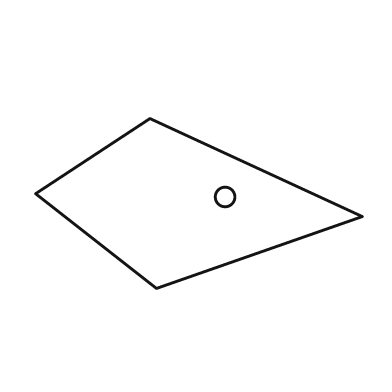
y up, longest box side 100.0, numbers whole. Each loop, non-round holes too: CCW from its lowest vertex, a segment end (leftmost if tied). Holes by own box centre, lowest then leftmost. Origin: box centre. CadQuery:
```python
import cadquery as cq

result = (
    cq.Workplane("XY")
    .moveTo(-13.0, -26.0)
    .lineTo(50.0, -4.0)
    .lineTo(-15.0, 26.0)
    .lineTo(-50.0, 3.0)
    .close()
    .moveTo(8.0, 2.0)
    .circle(3.0)
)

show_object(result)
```